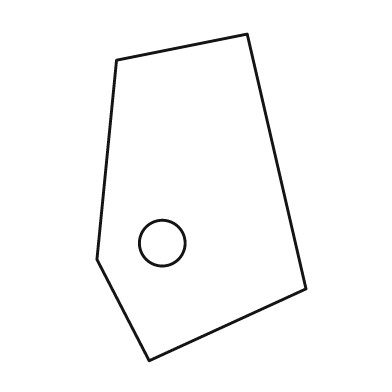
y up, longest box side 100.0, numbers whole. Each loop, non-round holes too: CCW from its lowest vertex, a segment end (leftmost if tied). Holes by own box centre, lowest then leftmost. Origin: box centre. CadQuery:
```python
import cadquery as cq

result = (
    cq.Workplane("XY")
    .moveTo(-16.0, -50.0)
    .lineTo(32.0, -28.0)
    .lineTo(14.0, 50.0)
    .lineTo(-26.0, 42.0)
    .lineTo(-32.0, -19.0)
    .close()
    .moveTo(-12.0, -14.0)
    .circle(7.0)
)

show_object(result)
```